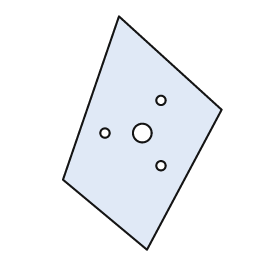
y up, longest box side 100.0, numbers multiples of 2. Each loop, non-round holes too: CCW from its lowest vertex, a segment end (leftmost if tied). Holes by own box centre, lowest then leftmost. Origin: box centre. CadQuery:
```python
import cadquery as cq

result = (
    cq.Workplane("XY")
    .moveTo(2.0, -50.0)
    .lineTo(34.0, 10.0)
    .lineTo(-10.0, 50.0)
    .lineTo(-34.0, -20.0)
    .close()
    .moveTo(8.0, -14.0)
    .circle(2.0)
    .moveTo(-16.0, 0.0)
    .circle(2.0)
    .moveTo(0.0, 0.0)
    .circle(4.0)
    .moveTo(8.0, 14.0)
    .circle(2.0)
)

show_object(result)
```